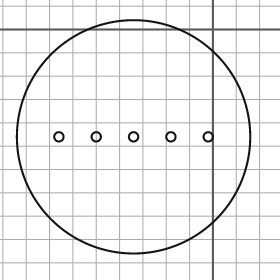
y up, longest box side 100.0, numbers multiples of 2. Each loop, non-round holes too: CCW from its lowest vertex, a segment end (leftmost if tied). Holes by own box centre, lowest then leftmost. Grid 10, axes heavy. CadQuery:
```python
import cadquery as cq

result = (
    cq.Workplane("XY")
    .moveTo(-34.0, -46.0)
    .circle(50.0)
    .moveTo(-66.0, -46.0)
    .circle(2.0)
    .moveTo(-50.0, -46.0)
    .circle(2.0)
    .moveTo(-34.0, -46.0)
    .circle(2.0)
    .moveTo(-18.0, -46.0)
    .circle(2.0)
    .moveTo(-2.0, -46.0)
    .circle(2.0)
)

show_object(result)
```